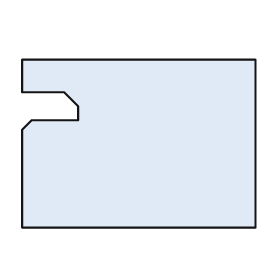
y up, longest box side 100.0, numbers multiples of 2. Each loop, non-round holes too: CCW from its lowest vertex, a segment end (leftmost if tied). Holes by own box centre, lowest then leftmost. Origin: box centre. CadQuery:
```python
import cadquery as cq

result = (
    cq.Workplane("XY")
    .moveTo(-50.0, -36.0)
    .lineTo(50.0, -36.0)
    .lineTo(50.0, 36.0)
    .lineTo(-50.0, 36.0)
    .lineTo(-50.0, 22.0)
    .lineTo(-32.0, 22.0)
    .lineTo(-26.0, 16.0)
    .lineTo(-26.0, 10.0)
    .lineTo(-46.0, 10.0)
    .lineTo(-50.0, 6.0)
    .close()
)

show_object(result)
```